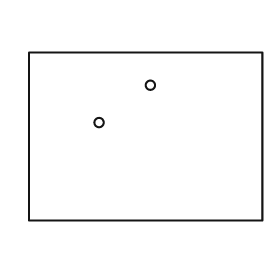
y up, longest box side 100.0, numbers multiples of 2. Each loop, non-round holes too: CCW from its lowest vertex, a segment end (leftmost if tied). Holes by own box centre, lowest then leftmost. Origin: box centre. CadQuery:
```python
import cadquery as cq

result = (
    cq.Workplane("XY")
    .moveTo(-50.0, -36.0)
    .lineTo(50.0, -36.0)
    .lineTo(50.0, 36.0)
    .lineTo(-50.0, 36.0)
    .close()
    .moveTo(-20.0, 6.0)
    .circle(2.0)
    .moveTo(2.0, 22.0)
    .circle(2.0)
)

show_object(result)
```